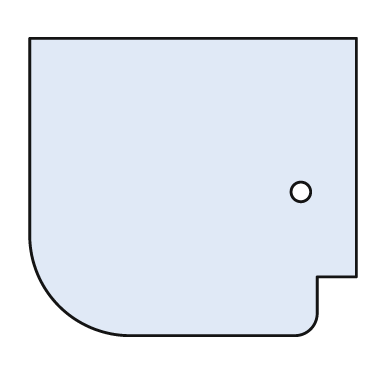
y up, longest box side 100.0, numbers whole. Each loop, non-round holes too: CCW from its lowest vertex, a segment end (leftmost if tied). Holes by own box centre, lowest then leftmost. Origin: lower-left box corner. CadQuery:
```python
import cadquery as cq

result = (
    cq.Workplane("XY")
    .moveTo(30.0, 0.0)
    .lineTo(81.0, 0.0)
    .threePointArc((86.0, 2.0), (88.0, 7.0))
    .lineTo(88.0, 18.0)
    .lineTo(100.0, 18.0)
    .lineTo(100.0, 91.0)
    .lineTo(0.0, 91.0)
    .lineTo(0.0, 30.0)
    .threePointArc((9.0, 9.0), (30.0, 0.0))
    .close()
    .moveTo(83.0, 44.0)
    .circle(3.0)
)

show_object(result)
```